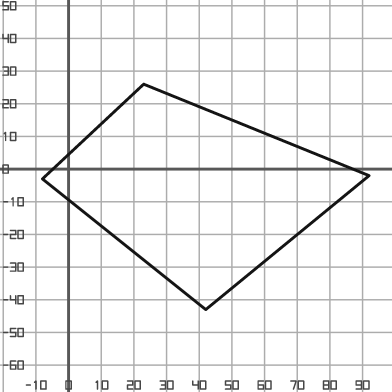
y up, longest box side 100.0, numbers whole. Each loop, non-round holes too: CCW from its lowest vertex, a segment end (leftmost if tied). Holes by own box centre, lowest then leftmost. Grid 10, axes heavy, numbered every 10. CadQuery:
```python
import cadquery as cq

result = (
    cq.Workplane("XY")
    .moveTo(42.0, -43.0)
    .lineTo(92.0, -2.0)
    .lineTo(23.0, 26.0)
    .lineTo(-8.0, -3.0)
    .close()
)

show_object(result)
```